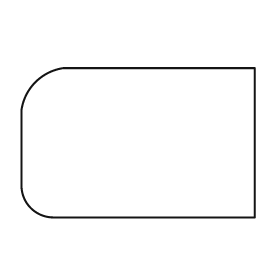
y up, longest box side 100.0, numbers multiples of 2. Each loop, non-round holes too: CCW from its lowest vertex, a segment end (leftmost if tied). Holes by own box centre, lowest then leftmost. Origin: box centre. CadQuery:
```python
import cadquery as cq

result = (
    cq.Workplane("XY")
    .moveTo(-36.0, -32.0)
    .lineTo(50.0, -32.0)
    .lineTo(50.0, 32.0)
    .lineTo(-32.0, 32.0)
    .threePointArc((-44.0, 26.0), (-50.0, 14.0))
    .lineTo(-50.0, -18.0)
    .threePointArc((-46.0, -28.0), (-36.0, -32.0))
    .close()
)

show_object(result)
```